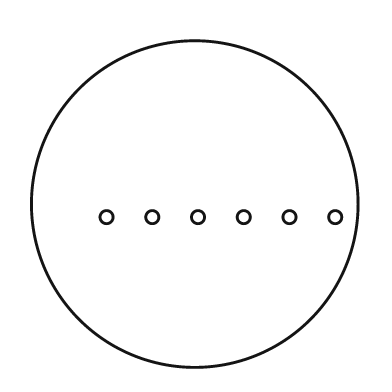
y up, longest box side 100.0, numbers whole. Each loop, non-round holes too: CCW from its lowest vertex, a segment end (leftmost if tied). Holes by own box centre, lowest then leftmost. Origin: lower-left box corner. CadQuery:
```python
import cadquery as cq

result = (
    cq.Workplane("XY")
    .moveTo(50.0, 50.0)
    .circle(50.0)
    .moveTo(23.0, 46.0)
    .circle(2.0)
    .moveTo(37.0, 46.0)
    .circle(2.0)
    .moveTo(51.0, 46.0)
    .circle(2.0)
    .moveTo(65.0, 46.0)
    .circle(2.0)
    .moveTo(79.0, 46.0)
    .circle(2.0)
    .moveTo(93.0, 46.0)
    .circle(2.0)
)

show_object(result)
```